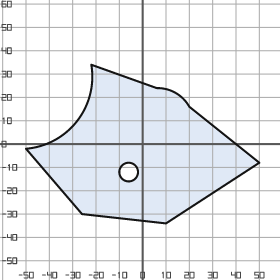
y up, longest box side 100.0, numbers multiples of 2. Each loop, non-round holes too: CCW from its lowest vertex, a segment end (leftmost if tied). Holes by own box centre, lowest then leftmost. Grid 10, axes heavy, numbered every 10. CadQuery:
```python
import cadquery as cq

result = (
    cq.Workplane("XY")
    .moveTo(10.0, -34.0)
    .lineTo(50.0, -8.0)
    .lineTo(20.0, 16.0)
    .threePointArc((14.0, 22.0), (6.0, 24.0))
    .lineTo(-22.0, 34.0)
    .threePointArc((-28.0, 10.0), (-50.0, -2.0))
    .lineTo(-26.0, -30.0)
    .close()
    .moveTo(-6.0, -12.0)
    .circle(4.0)
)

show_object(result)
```